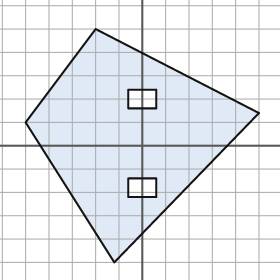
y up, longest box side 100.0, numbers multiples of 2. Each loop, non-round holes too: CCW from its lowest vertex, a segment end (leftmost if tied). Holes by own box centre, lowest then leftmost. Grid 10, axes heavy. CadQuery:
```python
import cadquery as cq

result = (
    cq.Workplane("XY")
    .moveTo(-12.0, -50.0)
    .lineTo(50.0, 14.0)
    .lineTo(-20.0, 50.0)
    .lineTo(-50.0, 10.0)
    .close()
    .moveTo(-6.0, -22.0)
    .lineTo(6.0, -22.0)
    .lineTo(6.0, -14.0)
    .lineTo(-6.0, -14.0)
    .close()
    .moveTo(-6.0, 16.0)
    .lineTo(6.0, 16.0)
    .lineTo(6.0, 24.0)
    .lineTo(-6.0, 24.0)
    .close()
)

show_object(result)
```